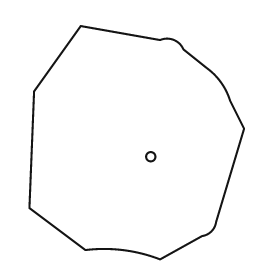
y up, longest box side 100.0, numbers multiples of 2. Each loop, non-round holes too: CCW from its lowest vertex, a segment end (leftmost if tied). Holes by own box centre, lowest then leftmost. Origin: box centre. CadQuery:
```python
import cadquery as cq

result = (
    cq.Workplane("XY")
    .moveTo(10.0, -50.0)
    .lineTo(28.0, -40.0)
    .threePointArc((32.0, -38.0), (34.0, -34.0))
    .lineTo(46.0, 6.0)
    .lineTo(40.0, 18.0)
    .threePointArc((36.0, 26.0), (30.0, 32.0))
    .lineTo(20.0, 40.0)
    .threePointArc((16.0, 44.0), (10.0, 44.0))
    .lineTo(-24.0, 50.0)
    .lineTo(-44.0, 22.0)
    .lineTo(-46.0, -28.0)
    .lineTo(-22.0, -46.0)
    .threePointArc((-6.0, -46.0), (10.0, -50.0))
    .close()
    .moveTo(6.0, -6.0)
    .circle(2.0)
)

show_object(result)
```